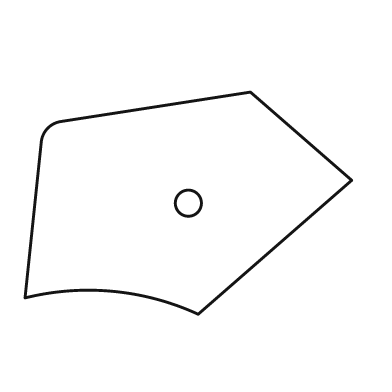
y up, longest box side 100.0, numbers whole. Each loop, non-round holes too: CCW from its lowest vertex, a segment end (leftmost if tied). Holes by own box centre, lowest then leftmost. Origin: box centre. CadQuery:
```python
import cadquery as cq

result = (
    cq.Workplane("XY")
    .moveTo(3.0, -34.0)
    .lineTo(50.0, 7.0)
    .lineTo(19.0, 34.0)
    .lineTo(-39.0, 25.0)
    .threePointArc((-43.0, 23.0), (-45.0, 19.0))
    .lineTo(-50.0, -29.0)
    .threePointArc((-23.0, -27.0), (3.0, -34.0))
    .close()
    .moveTo(0.0, 0.0)
    .circle(4.0)
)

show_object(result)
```